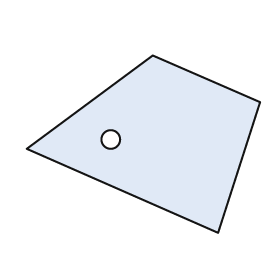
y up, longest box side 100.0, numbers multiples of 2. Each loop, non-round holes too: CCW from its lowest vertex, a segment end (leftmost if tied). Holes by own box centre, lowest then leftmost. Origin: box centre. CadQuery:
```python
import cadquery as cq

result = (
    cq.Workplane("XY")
    .moveTo(32.0, -38.0)
    .lineTo(50.0, 18.0)
    .lineTo(4.0, 38.0)
    .lineTo(-50.0, -2.0)
    .close()
    .moveTo(-14.0, 2.0)
    .circle(4.0)
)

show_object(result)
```